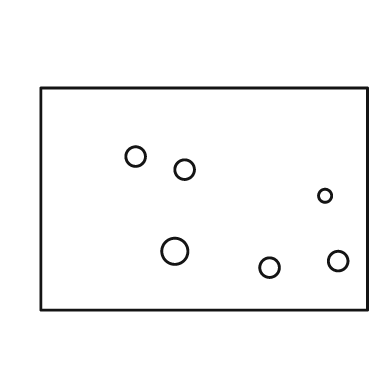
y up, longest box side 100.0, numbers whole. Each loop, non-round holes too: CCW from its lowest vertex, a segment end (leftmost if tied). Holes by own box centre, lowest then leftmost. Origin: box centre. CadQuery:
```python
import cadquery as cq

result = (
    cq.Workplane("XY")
    .moveTo(-50.0, -34.0)
    .lineTo(50.0, -34.0)
    .lineTo(50.0, 34.0)
    .lineTo(-50.0, 34.0)
    .close()
    .moveTo(20.0, -21.0)
    .circle(3.0)
    .moveTo(41.0, -19.0)
    .circle(3.0)
    .moveTo(-9.0, -16.0)
    .circle(4.0)
    .moveTo(37.0, 1.0)
    .circle(2.0)
    .moveTo(-6.0, 9.0)
    .circle(3.0)
    .moveTo(-21.0, 13.0)
    .circle(3.0)
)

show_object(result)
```